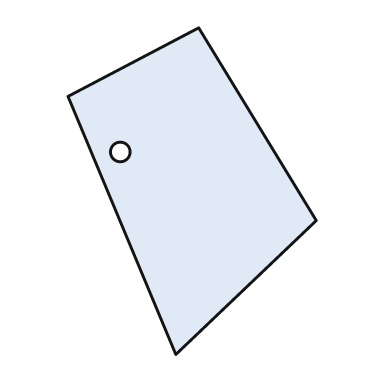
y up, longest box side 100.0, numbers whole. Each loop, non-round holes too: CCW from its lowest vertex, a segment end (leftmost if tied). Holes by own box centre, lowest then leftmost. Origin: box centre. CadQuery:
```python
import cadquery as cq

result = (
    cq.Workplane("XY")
    .moveTo(-5.0, -50.0)
    .lineTo(38.0, -9.0)
    .lineTo(2.0, 50.0)
    .lineTo(-38.0, 29.0)
    .close()
    .moveTo(-22.0, 12.0)
    .circle(3.0)
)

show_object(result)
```